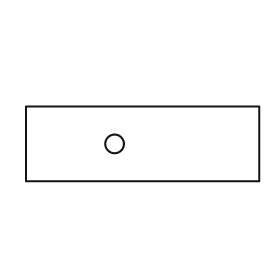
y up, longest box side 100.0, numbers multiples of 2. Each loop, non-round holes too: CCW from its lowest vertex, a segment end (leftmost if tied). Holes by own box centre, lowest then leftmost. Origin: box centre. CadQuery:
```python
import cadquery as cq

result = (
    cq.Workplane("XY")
    .moveTo(-50.0, -16.0)
    .lineTo(50.0, -16.0)
    .lineTo(50.0, 16.0)
    .lineTo(-50.0, 16.0)
    .close()
    .moveTo(-12.0, 0.0)
    .circle(4.0)
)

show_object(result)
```